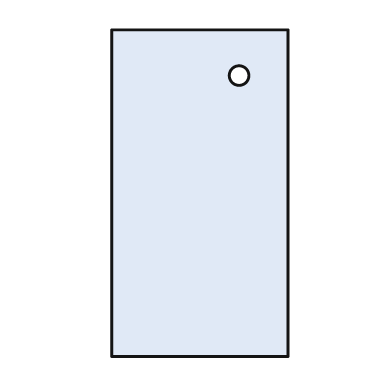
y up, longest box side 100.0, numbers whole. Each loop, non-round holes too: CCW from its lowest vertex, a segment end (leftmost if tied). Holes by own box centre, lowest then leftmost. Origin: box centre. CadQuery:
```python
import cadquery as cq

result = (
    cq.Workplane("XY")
    .moveTo(-27.0, -50.0)
    .lineTo(27.0, -50.0)
    .lineTo(27.0, 50.0)
    .lineTo(-27.0, 50.0)
    .close()
    .moveTo(12.0, 36.0)
    .circle(3.0)
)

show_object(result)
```